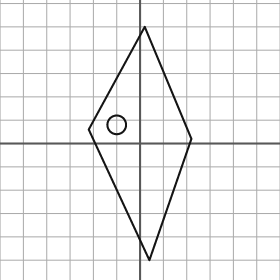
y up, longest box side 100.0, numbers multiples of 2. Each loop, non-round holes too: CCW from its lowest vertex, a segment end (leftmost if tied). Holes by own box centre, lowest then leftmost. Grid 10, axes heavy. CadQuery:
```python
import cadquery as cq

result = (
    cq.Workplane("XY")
    .moveTo(4.0, -50.0)
    .lineTo(22.0, 2.0)
    .lineTo(2.0, 50.0)
    .lineTo(-22.0, 6.0)
    .close()
    .moveTo(-10.0, 8.0)
    .circle(4.0)
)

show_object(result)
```